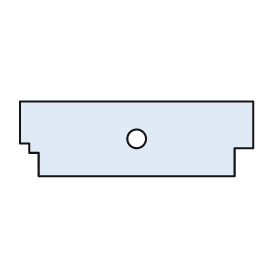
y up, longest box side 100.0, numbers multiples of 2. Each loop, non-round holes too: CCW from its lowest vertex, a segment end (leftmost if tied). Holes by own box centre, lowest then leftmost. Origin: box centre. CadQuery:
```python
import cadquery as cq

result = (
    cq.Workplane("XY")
    .moveTo(-42.0, -16.0)
    .lineTo(42.0, -16.0)
    .lineTo(42.0, -4.0)
    .lineTo(50.0, -4.0)
    .lineTo(50.0, 16.0)
    .lineTo(-50.0, 16.0)
    .lineTo(-50.0, -2.0)
    .lineTo(-46.0, -2.0)
    .lineTo(-46.0, -6.0)
    .lineTo(-42.0, -6.0)
    .close()
    .moveTo(0.0, 0.0)
    .circle(4.0)
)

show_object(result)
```